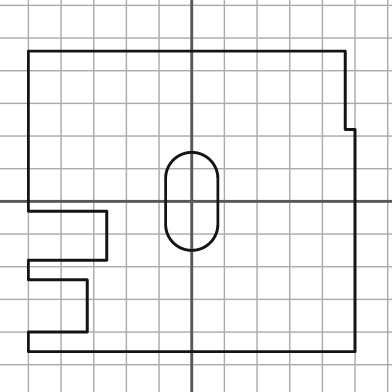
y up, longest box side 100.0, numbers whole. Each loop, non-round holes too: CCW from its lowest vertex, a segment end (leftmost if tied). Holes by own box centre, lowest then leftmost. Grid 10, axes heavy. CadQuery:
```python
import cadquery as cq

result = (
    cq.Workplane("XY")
    .moveTo(-50.0, -46.0)
    .lineTo(50.0, -46.0)
    .lineTo(50.0, 22.0)
    .lineTo(47.0, 22.0)
    .lineTo(47.0, 46.0)
    .lineTo(-50.0, 46.0)
    .lineTo(-50.0, -3.0)
    .lineTo(-26.0, -3.0)
    .lineTo(-26.0, -18.0)
    .lineTo(-50.0, -18.0)
    .lineTo(-50.0, -24.0)
    .lineTo(-32.0, -24.0)
    .lineTo(-32.0, -40.0)
    .lineTo(-50.0, -40.0)
    .close()
    .moveTo(-8.0, -7.0)
    .threePointArc((0.0, -15.0), (8.0, -7.0))
    .lineTo(8.0, 7.0)
    .threePointArc((0.0, 15.0), (-8.0, 7.0))
    .close()
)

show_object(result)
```